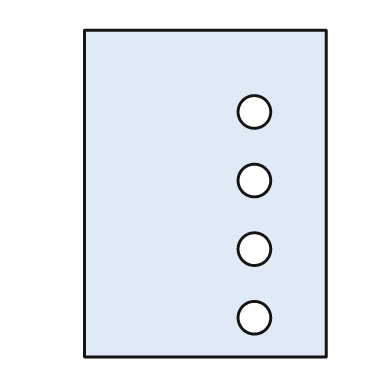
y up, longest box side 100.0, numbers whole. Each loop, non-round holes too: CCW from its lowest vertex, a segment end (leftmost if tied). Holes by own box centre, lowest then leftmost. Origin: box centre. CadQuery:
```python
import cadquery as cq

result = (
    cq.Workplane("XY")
    .moveTo(-37.0, -50.0)
    .lineTo(37.0, -50.0)
    .lineTo(37.0, 50.0)
    .lineTo(-37.0, 50.0)
    .close()
    .moveTo(15.0, -38.0)
    .circle(5.0)
    .moveTo(15.0, -17.0)
    .circle(5.0)
    .moveTo(15.0, 4.0)
    .circle(5.0)
    .moveTo(15.0, 25.0)
    .circle(5.0)
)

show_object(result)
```